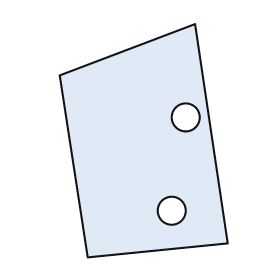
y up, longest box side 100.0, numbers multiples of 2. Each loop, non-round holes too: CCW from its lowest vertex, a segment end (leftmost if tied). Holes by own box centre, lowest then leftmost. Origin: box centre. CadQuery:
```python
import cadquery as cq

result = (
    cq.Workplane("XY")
    .moveTo(-24.0, -50.0)
    .lineTo(36.0, -44.0)
    .lineTo(22.0, 50.0)
    .lineTo(-36.0, 28.0)
    .close()
    .moveTo(12.0, -30.0)
    .circle(6.0)
    .moveTo(18.0, 10.0)
    .circle(6.0)
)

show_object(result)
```